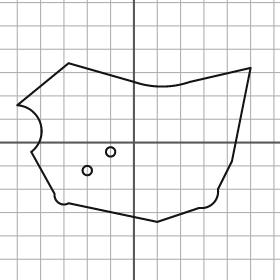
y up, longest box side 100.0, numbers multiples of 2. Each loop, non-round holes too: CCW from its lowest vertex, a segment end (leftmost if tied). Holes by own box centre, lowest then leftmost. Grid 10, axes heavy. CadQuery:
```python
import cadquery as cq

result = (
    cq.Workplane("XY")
    .moveTo(10.0, -34.0)
    .lineTo(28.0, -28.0)
    .threePointArc((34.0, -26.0), (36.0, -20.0))
    .lineTo(42.0, -8.0)
    .lineTo(50.0, 32.0)
    .lineTo(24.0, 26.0)
    .threePointArc((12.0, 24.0), (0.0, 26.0))
    .lineTo(-28.0, 34.0)
    .lineTo(-50.0, 16.0)
    .threePointArc((-40.0, 8.0), (-44.0, -4.0))
    .lineTo(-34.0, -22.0)
    .threePointArc((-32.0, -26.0), (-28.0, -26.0))
    .close()
    .moveTo(-20.0, -12.0)
    .circle(2.0)
    .moveTo(-10.0, -4.0)
    .circle(2.0)
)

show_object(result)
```